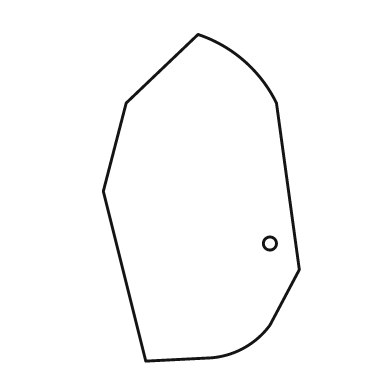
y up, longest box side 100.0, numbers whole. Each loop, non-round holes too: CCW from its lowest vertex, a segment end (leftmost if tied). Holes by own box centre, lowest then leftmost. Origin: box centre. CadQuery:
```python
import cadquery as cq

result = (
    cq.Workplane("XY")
    .moveTo(-17.0, -50.0)
    .lineTo(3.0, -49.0)
    .threePointArc((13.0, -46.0), (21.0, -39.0))
    .lineTo(30.0, -22.0)
    .lineTo(23.0, 29.0)
    .threePointArc((13.0, 42.0), (-1.0, 50.0))
    .lineTo(-23.0, 29.0)
    .lineTo(-30.0, 2.0)
    .close()
    .moveTo(21.0, -14.0)
    .circle(2.0)
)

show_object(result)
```